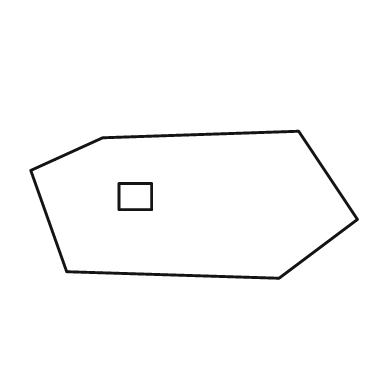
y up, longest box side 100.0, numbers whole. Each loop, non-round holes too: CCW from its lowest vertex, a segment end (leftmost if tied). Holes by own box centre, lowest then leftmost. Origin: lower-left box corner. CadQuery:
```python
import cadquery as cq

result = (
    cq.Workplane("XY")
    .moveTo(76.0, 0.0)
    .lineTo(100.0, 18.0)
    .lineTo(82.0, 45.0)
    .lineTo(22.0, 43.0)
    .lineTo(0.0, 33.0)
    .lineTo(11.0, 2.0)
    .close()
    .moveTo(27.0, 21.0)
    .lineTo(37.0, 21.0)
    .lineTo(37.0, 29.0)
    .lineTo(27.0, 29.0)
    .close()
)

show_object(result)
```